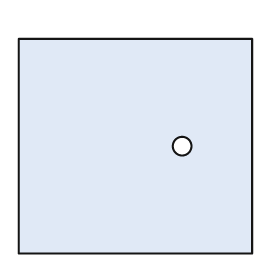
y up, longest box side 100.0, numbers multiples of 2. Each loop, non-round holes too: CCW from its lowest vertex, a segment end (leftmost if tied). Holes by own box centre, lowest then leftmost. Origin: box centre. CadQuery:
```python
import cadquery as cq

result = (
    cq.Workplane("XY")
    .moveTo(-50.0, -46.0)
    .lineTo(50.0, -46.0)
    .lineTo(50.0, 46.0)
    .lineTo(-50.0, 46.0)
    .close()
    .moveTo(20.0, 0.0)
    .circle(4.0)
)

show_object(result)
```